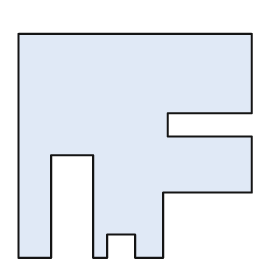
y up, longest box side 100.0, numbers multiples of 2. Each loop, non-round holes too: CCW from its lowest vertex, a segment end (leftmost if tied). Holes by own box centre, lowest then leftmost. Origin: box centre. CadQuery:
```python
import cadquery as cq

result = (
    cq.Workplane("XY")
    .moveTo(-50.0, -48.0)
    .lineTo(-36.0, -48.0)
    .lineTo(-36.0, -4.0)
    .lineTo(-18.0, -4.0)
    .lineTo(-18.0, -48.0)
    .lineTo(-12.0, -48.0)
    .lineTo(-12.0, -38.0)
    .lineTo(0.0, -38.0)
    .lineTo(0.0, -48.0)
    .lineTo(12.0, -48.0)
    .lineTo(12.0, -20.0)
    .lineTo(50.0, -20.0)
    .lineTo(50.0, 4.0)
    .lineTo(14.0, 4.0)
    .lineTo(14.0, 14.0)
    .lineTo(50.0, 14.0)
    .lineTo(50.0, 48.0)
    .lineTo(-50.0, 48.0)
    .close()
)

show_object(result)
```